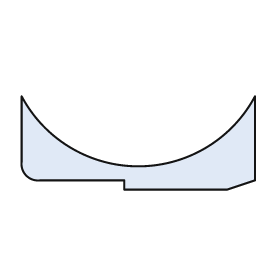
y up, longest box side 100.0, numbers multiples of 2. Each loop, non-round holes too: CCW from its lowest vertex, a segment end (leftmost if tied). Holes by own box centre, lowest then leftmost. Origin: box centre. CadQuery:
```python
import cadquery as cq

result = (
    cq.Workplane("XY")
    .moveTo(-6.0, -20.0)
    .lineTo(38.0, -20.0)
    .lineTo(50.0, -16.0)
    .lineTo(50.0, 20.0)
    .threePointArc((0.0, -10.0), (-50.0, 20.0))
    .lineTo(-50.0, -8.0)
    .threePointArc((-48.0, -14.0), (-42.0, -16.0))
    .lineTo(-6.0, -16.0)
    .close()
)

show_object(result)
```